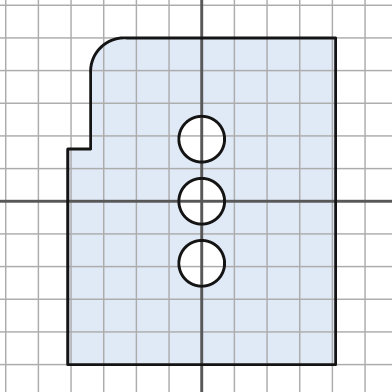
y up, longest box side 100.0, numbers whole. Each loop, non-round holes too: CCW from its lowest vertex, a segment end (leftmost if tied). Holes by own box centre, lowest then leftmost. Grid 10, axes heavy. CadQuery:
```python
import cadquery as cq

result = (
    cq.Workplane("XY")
    .moveTo(-41.0, -50.0)
    .lineTo(41.0, -50.0)
    .lineTo(41.0, 50.0)
    .lineTo(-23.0, 50.0)
    .threePointArc((-31.0, 47.0), (-34.0, 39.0))
    .lineTo(-34.0, 16.0)
    .lineTo(-41.0, 16.0)
    .close()
    .moveTo(0.0, -19.0)
    .circle(7.0)
    .moveTo(0.0, 0.0)
    .circle(7.0)
    .moveTo(0.0, 19.0)
    .circle(7.0)
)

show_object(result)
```